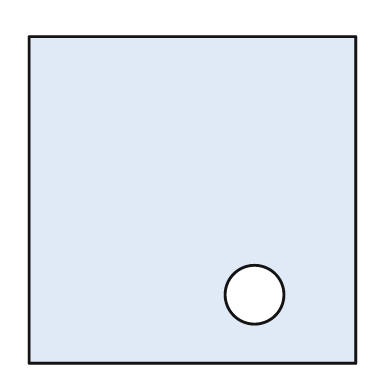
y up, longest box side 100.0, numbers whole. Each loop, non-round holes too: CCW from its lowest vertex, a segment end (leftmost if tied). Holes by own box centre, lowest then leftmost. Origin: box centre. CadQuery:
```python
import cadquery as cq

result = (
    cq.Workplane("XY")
    .moveTo(-50.0, -50.0)
    .lineTo(50.0, -50.0)
    .lineTo(50.0, 50.0)
    .lineTo(-50.0, 50.0)
    .close()
    .moveTo(19.0, -29.0)
    .circle(9.0)
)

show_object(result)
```